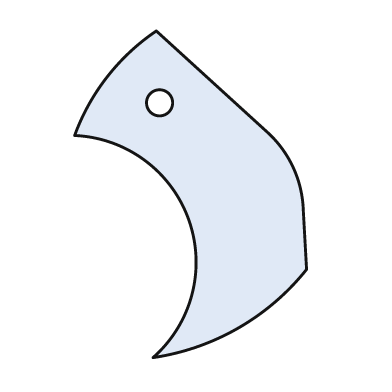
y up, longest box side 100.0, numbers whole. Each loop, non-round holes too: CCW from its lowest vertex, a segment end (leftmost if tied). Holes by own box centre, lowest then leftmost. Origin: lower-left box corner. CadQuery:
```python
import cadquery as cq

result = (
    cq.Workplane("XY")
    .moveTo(24.0, 0.0)
    .threePointArc((50.0, 9.0), (71.0, 27.0))
    .lineTo(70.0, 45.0)
    .threePointArc((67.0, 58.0), (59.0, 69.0))
    .lineTo(25.0, 100.0)
    .threePointArc((10.0, 86.0), (0.0, 68.0))
    .threePointArc((35.0, 42.0), (24.0, 0.0))
    .close()
    .moveTo(26.0, 78.0)
    .circle(4.0)
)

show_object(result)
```